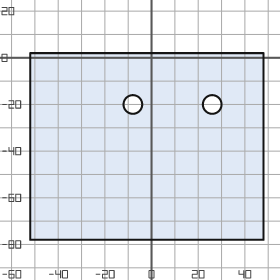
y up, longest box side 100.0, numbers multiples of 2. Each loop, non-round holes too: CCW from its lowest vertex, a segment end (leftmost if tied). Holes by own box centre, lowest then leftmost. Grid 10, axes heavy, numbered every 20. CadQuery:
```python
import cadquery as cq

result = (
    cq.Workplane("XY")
    .moveTo(-52.0, -78.0)
    .lineTo(48.0, -78.0)
    .lineTo(48.0, 2.0)
    .lineTo(-52.0, 2.0)
    .close()
    .moveTo(-8.0, -20.0)
    .circle(4.0)
    .moveTo(26.0, -20.0)
    .circle(4.0)
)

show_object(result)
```